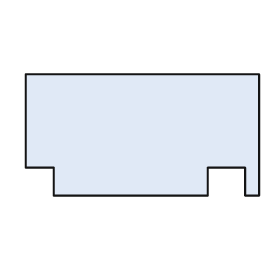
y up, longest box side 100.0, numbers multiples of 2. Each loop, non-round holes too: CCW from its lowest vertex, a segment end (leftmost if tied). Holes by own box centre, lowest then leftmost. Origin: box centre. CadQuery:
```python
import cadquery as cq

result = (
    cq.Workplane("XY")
    .moveTo(-38.0, -26.0)
    .lineTo(28.0, -26.0)
    .lineTo(28.0, -14.0)
    .lineTo(44.0, -14.0)
    .lineTo(44.0, -26.0)
    .lineTo(50.0, -26.0)
    .lineTo(50.0, 26.0)
    .lineTo(-50.0, 26.0)
    .lineTo(-50.0, -14.0)
    .lineTo(-38.0, -14.0)
    .close()
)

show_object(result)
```